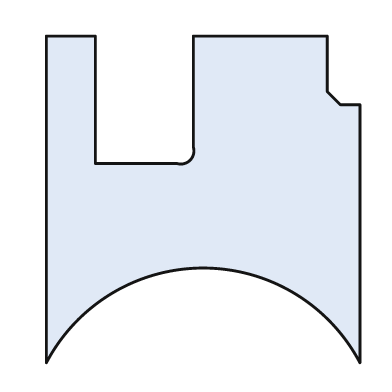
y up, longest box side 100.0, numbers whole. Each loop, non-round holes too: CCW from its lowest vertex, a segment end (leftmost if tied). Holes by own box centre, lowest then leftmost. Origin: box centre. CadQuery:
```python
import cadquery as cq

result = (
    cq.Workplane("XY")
    .moveTo(-48.0, -50.0)
    .threePointArc((0.0, -21.0), (48.0, -50.0))
    .lineTo(48.0, 29.0)
    .lineTo(42.0, 29.0)
    .lineTo(38.0, 33.0)
    .lineTo(38.0, 50.0)
    .lineTo(-3.0, 50.0)
    .lineTo(-3.0, 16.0)
    .threePointArc((-4.0, 12.0), (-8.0, 11.0))
    .lineTo(-33.0, 11.0)
    .lineTo(-33.0, 50.0)
    .lineTo(-48.0, 50.0)
    .close()
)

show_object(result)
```